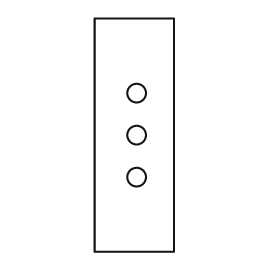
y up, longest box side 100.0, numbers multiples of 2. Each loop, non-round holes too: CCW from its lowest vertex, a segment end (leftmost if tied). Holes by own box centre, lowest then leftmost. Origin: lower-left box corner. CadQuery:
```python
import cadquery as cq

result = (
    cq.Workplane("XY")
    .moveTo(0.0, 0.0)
    .lineTo(34.0, 0.0)
    .lineTo(34.0, 100.0)
    .lineTo(0.0, 100.0)
    .close()
    .moveTo(18.0, 32.0)
    .circle(4.0)
    .moveTo(18.0, 50.0)
    .circle(4.0)
    .moveTo(18.0, 68.0)
    .circle(4.0)
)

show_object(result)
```